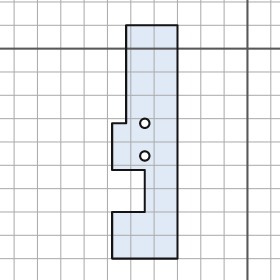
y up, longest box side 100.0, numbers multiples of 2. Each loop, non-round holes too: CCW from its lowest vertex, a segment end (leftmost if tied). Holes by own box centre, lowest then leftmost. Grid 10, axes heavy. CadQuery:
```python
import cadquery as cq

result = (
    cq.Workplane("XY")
    .moveTo(-58.0, -90.0)
    .lineTo(-30.0, -90.0)
    .lineTo(-30.0, 10.0)
    .lineTo(-52.0, 10.0)
    .lineTo(-52.0, -32.0)
    .lineTo(-58.0, -32.0)
    .lineTo(-58.0, -52.0)
    .lineTo(-44.0, -52.0)
    .lineTo(-44.0, -70.0)
    .lineTo(-58.0, -70.0)
    .close()
    .moveTo(-44.0, -46.0)
    .circle(2.0)
    .moveTo(-44.0, -32.0)
    .circle(2.0)
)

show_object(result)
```